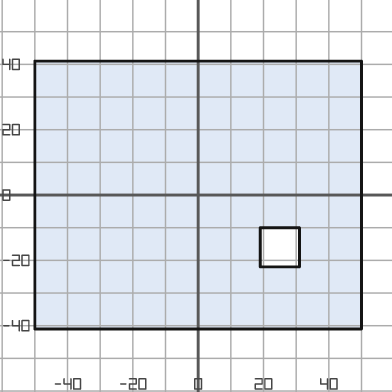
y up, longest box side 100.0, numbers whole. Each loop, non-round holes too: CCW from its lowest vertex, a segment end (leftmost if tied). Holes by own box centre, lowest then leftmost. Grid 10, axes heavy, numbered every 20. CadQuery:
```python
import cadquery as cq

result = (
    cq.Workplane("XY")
    .moveTo(-50.0, -41.0)
    .lineTo(50.0, -41.0)
    .lineTo(50.0, 41.0)
    .lineTo(-50.0, 41.0)
    .close()
    .moveTo(19.0, -22.0)
    .lineTo(31.0, -22.0)
    .lineTo(31.0, -10.0)
    .lineTo(19.0, -10.0)
    .close()
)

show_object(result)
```